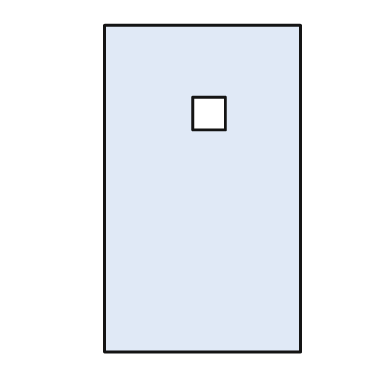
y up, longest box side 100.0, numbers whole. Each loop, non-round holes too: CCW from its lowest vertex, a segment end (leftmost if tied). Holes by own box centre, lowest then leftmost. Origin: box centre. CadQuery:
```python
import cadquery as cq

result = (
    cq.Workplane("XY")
    .moveTo(-30.0, -50.0)
    .lineTo(30.0, -50.0)
    .lineTo(30.0, 50.0)
    .lineTo(-30.0, 50.0)
    .close()
    .moveTo(-3.0, 18.0)
    .lineTo(7.0, 18.0)
    .lineTo(7.0, 28.0)
    .lineTo(-3.0, 28.0)
    .close()
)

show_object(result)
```